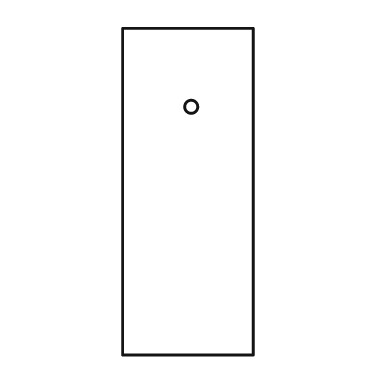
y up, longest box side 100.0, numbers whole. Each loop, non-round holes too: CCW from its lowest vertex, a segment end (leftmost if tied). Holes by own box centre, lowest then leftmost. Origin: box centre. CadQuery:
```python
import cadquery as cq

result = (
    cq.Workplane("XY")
    .moveTo(-20.0, -50.0)
    .lineTo(20.0, -50.0)
    .lineTo(20.0, 50.0)
    .lineTo(-20.0, 50.0)
    .close()
    .moveTo(1.0, 26.0)
    .circle(2.0)
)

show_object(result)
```